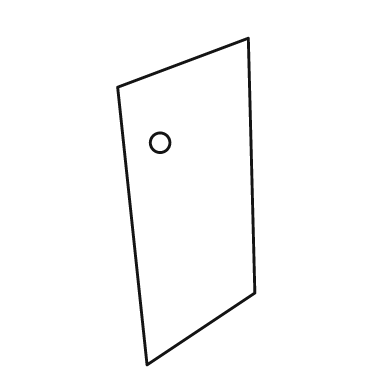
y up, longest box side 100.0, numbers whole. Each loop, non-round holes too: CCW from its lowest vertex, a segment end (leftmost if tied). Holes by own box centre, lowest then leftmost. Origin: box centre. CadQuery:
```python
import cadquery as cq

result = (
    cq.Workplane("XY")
    .moveTo(-12.0, -50.0)
    .lineTo(21.0, -28.0)
    .lineTo(19.0, 50.0)
    .lineTo(-21.0, 35.0)
    .close()
    .moveTo(-8.0, 18.0)
    .circle(3.0)
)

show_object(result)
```